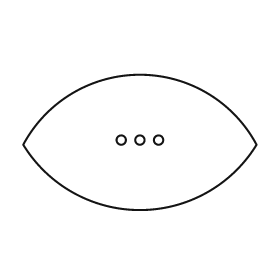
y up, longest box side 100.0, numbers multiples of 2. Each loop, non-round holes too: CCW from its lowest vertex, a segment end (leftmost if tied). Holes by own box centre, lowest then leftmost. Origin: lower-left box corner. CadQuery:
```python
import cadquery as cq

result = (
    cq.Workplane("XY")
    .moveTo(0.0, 28.0)
    .threePointArc((50.0, 0.0), (100.0, 28.0))
    .threePointArc((50.0, 58.0), (0.0, 28.0))
    .close()
    .moveTo(42.0, 30.0)
    .circle(2.0)
    .moveTo(50.0, 30.0)
    .circle(2.0)
    .moveTo(58.0, 30.0)
    .circle(2.0)
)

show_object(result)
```